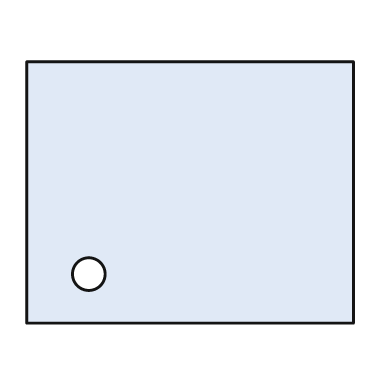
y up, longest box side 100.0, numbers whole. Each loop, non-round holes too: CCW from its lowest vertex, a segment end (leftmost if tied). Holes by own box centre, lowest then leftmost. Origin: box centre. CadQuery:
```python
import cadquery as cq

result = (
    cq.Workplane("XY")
    .moveTo(-50.0, -40.0)
    .lineTo(50.0, -40.0)
    .lineTo(50.0, 40.0)
    .lineTo(-50.0, 40.0)
    .close()
    .moveTo(-31.0, -25.0)
    .circle(5.0)
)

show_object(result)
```